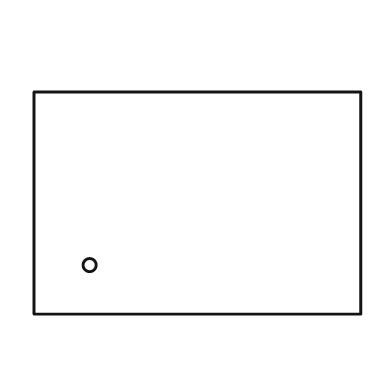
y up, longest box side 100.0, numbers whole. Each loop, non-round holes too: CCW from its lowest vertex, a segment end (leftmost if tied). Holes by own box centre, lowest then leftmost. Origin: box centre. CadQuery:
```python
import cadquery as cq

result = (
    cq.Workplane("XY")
    .moveTo(-50.0, -34.0)
    .lineTo(50.0, -34.0)
    .lineTo(50.0, 34.0)
    .lineTo(-50.0, 34.0)
    .close()
    .moveTo(-33.0, -19.0)
    .circle(2.0)
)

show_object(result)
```